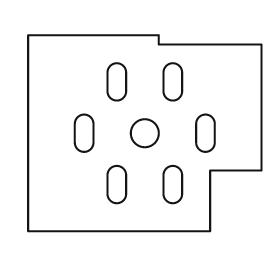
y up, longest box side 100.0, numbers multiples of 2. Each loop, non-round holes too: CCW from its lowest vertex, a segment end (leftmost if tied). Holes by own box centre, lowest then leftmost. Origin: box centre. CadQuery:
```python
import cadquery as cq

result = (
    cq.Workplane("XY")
    .moveTo(-50.0, -42.0)
    .lineTo(28.0, -42.0)
    .lineTo(28.0, -16.0)
    .lineTo(50.0, -16.0)
    .lineTo(50.0, 38.0)
    .lineTo(6.0, 38.0)
    .lineTo(6.0, 42.0)
    .lineTo(-50.0, 42.0)
    .close()
    .moveTo(-16.0, -26.0)
    .threePointArc((-12.0, -30.0), (-8.0, -26.0))
    .lineTo(-8.0, -18.0)
    .threePointArc((-12.0, -14.0), (-16.0, -18.0))
    .close()
    .moveTo(8.0, -26.0)
    .threePointArc((12.0, -30.0), (16.0, -26.0))
    .lineTo(16.0, -18.0)
    .threePointArc((12.0, -14.0), (8.0, -18.0))
    .close()
    .moveTo(-30.0, -4.0)
    .threePointArc((-26.0, -8.0), (-22.0, -4.0))
    .lineTo(-22.0, 4.0)
    .threePointArc((-26.0, 8.0), (-30.0, 4.0))
    .close()
    .moveTo(0.0, 0.0)
    .circle(6.0)
    .moveTo(22.0, -4.0)
    .threePointArc((26.0, -8.0), (30.0, -4.0))
    .lineTo(30.0, 4.0)
    .threePointArc((26.0, 8.0), (22.0, 4.0))
    .close()
    .moveTo(-16.0, 18.0)
    .threePointArc((-12.0, 14.0), (-8.0, 18.0))
    .lineTo(-8.0, 26.0)
    .threePointArc((-12.0, 30.0), (-16.0, 26.0))
    .close()
    .moveTo(8.0, 18.0)
    .threePointArc((12.0, 14.0), (16.0, 18.0))
    .lineTo(16.0, 26.0)
    .threePointArc((12.0, 30.0), (8.0, 26.0))
    .close()
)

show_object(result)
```